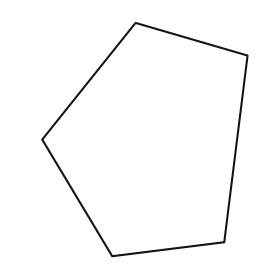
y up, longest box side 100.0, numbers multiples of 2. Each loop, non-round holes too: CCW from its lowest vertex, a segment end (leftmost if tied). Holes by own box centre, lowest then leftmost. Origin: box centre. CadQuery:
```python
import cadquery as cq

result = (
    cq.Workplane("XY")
    .moveTo(-14.0, -50.0)
    .lineTo(34.0, -44.0)
    .lineTo(44.0, 36.0)
    .lineTo(-4.0, 50.0)
    .lineTo(-44.0, 0.0)
    .close()
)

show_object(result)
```